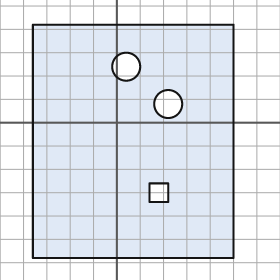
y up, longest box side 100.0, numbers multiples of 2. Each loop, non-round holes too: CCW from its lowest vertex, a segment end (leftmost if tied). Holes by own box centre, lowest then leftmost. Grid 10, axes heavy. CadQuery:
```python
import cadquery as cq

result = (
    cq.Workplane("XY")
    .moveTo(-36.0, -58.0)
    .lineTo(50.0, -58.0)
    .lineTo(50.0, 42.0)
    .lineTo(-36.0, 42.0)
    .close()
    .moveTo(14.0, -34.0)
    .lineTo(22.0, -34.0)
    .lineTo(22.0, -26.0)
    .lineTo(14.0, -26.0)
    .close()
    .moveTo(22.0, 8.0)
    .circle(6.0)
    .moveTo(4.0, 24.0)
    .circle(6.0)
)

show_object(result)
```